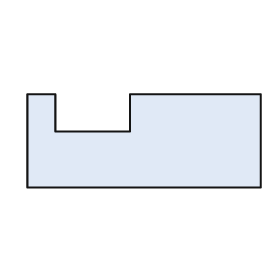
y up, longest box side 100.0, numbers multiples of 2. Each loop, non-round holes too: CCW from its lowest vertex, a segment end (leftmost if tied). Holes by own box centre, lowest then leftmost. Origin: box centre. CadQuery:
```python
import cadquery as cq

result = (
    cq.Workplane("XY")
    .moveTo(-50.0, -20.0)
    .lineTo(50.0, -20.0)
    .lineTo(50.0, 20.0)
    .lineTo(-6.0, 20.0)
    .lineTo(-6.0, 4.0)
    .lineTo(-38.0, 4.0)
    .lineTo(-38.0, 20.0)
    .lineTo(-50.0, 20.0)
    .close()
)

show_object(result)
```